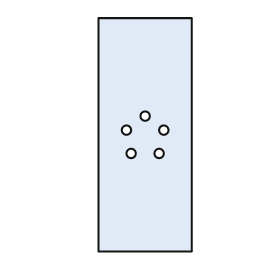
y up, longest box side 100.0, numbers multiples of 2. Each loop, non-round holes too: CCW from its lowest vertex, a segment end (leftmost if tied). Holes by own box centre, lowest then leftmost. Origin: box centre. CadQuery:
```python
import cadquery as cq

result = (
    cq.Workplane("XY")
    .moveTo(-20.0, -50.0)
    .lineTo(20.0, -50.0)
    .lineTo(20.0, 50.0)
    .lineTo(-20.0, 50.0)
    .close()
    .moveTo(-6.0, -8.0)
    .circle(2.0)
    .moveTo(6.0, -8.0)
    .circle(2.0)
    .moveTo(-8.0, 2.0)
    .circle(2.0)
    .moveTo(8.0, 2.0)
    .circle(2.0)
    .moveTo(0.0, 8.0)
    .circle(2.0)
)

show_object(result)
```